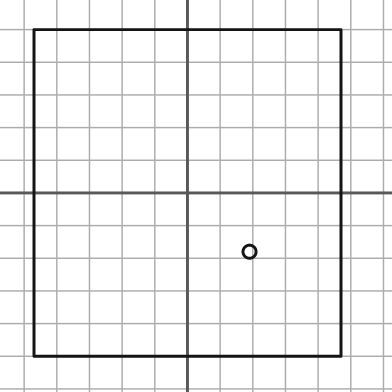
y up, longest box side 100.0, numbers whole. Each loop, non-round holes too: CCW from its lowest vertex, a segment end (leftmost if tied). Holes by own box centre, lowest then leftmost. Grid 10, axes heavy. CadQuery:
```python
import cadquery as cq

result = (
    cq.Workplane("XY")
    .moveTo(-47.0, -50.0)
    .lineTo(47.0, -50.0)
    .lineTo(47.0, 50.0)
    .lineTo(-47.0, 50.0)
    .close()
    .moveTo(19.0, -18.0)
    .circle(2.0)
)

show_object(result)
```